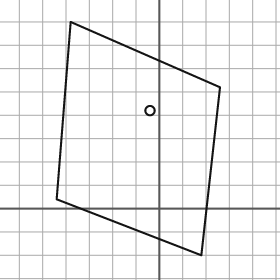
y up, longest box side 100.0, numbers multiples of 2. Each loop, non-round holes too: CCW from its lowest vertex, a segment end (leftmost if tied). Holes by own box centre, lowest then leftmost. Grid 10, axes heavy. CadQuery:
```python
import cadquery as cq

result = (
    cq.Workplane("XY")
    .moveTo(18.0, -20.0)
    .lineTo(26.0, 52.0)
    .lineTo(-38.0, 80.0)
    .lineTo(-44.0, 4.0)
    .close()
    .moveTo(-4.0, 42.0)
    .circle(2.0)
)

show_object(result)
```